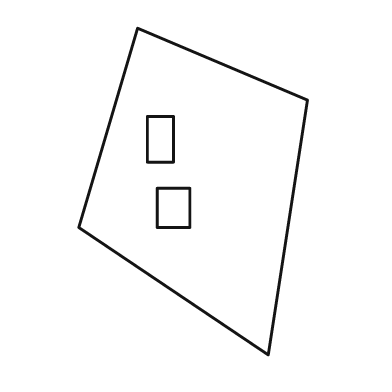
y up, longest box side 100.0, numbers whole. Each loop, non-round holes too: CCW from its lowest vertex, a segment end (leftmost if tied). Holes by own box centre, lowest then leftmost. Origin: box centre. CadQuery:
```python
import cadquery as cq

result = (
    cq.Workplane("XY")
    .moveTo(23.0, -50.0)
    .lineTo(35.0, 28.0)
    .lineTo(-17.0, 50.0)
    .lineTo(-35.0, -11.0)
    .close()
    .moveTo(-11.0, -11.0)
    .lineTo(-1.0, -11.0)
    .lineTo(-1.0, 1.0)
    .lineTo(-11.0, 1.0)
    .close()
    .moveTo(-14.0, 9.0)
    .lineTo(-6.0, 9.0)
    .lineTo(-6.0, 23.0)
    .lineTo(-14.0, 23.0)
    .close()
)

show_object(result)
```